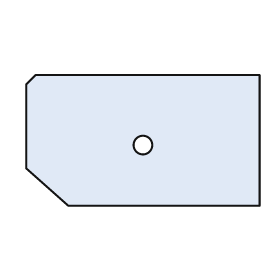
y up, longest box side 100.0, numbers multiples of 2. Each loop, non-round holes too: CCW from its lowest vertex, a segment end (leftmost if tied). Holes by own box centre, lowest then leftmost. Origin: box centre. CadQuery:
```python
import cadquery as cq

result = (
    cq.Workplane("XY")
    .moveTo(-32.0, -28.0)
    .lineTo(50.0, -28.0)
    .lineTo(50.0, 28.0)
    .lineTo(-46.0, 28.0)
    .lineTo(-50.0, 24.0)
    .lineTo(-50.0, -12.0)
    .close()
    .moveTo(0.0, -2.0)
    .circle(4.0)
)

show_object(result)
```